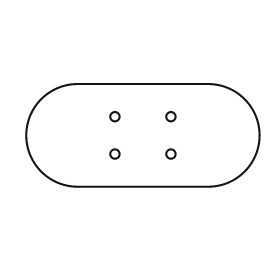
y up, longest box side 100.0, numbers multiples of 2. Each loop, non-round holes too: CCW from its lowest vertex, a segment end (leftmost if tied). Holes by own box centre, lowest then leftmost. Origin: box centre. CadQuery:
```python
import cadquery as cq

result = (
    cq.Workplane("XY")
    .moveTo(-28.0, -22.0)
    .lineTo(28.0, -22.0)
    .threePointArc((50.0, 0.0), (28.0, 22.0))
    .lineTo(-28.0, 22.0)
    .threePointArc((-50.0, 0.0), (-28.0, -22.0))
    .close()
    .moveTo(-12.0, -8.0)
    .circle(2.0)
    .moveTo(12.0, -8.0)
    .circle(2.0)
    .moveTo(-12.0, 8.0)
    .circle(2.0)
    .moveTo(12.0, 8.0)
    .circle(2.0)
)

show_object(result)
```